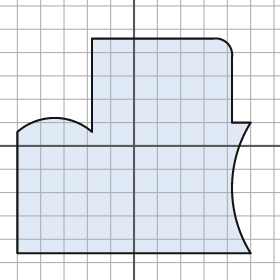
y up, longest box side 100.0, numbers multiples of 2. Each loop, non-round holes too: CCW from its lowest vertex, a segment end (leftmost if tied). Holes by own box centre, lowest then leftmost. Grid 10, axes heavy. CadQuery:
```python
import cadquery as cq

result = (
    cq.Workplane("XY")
    .moveTo(-50.0, -46.0)
    .lineTo(50.0, -46.0)
    .threePointArc((42.0, -18.0), (50.0, 10.0))
    .lineTo(42.0, 10.0)
    .lineTo(42.0, 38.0)
    .threePointArc((40.0, 44.0), (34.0, 46.0))
    .lineTo(-18.0, 46.0)
    .lineTo(-18.0, 6.0)
    .threePointArc((-34.0, 12.0), (-50.0, 6.0))
    .close()
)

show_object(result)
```